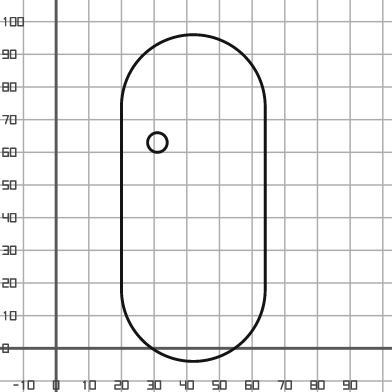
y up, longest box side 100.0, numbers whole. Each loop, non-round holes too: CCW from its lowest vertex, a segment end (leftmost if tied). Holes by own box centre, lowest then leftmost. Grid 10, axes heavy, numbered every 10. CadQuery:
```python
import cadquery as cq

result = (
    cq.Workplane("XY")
    .moveTo(20.0, 18.0)
    .threePointArc((42.0, -4.0), (64.0, 18.0))
    .lineTo(64.0, 74.0)
    .threePointArc((42.0, 96.0), (20.0, 74.0))
    .close()
    .moveTo(31.0, 63.0)
    .circle(3.0)
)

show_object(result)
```